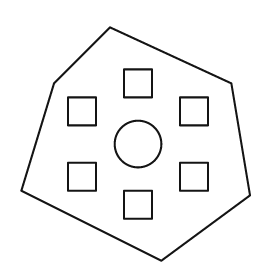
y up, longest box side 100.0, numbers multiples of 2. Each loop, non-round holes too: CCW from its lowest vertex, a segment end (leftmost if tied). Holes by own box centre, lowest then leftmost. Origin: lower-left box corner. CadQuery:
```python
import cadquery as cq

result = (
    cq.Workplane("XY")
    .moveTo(60.0, 0.0)
    .lineTo(98.0, 28.0)
    .lineTo(90.0, 76.0)
    .lineTo(38.0, 100.0)
    .lineTo(14.0, 76.0)
    .lineTo(0.0, 30.0)
    .close()
    .moveTo(44.0, 18.0)
    .lineTo(56.0, 18.0)
    .lineTo(56.0, 30.0)
    .lineTo(44.0, 30.0)
    .close()
    .moveTo(20.0, 30.0)
    .lineTo(32.0, 30.0)
    .lineTo(32.0, 42.0)
    .lineTo(20.0, 42.0)
    .close()
    .moveTo(68.0, 30.0)
    .lineTo(80.0, 30.0)
    .lineTo(80.0, 42.0)
    .lineTo(68.0, 42.0)
    .close()
    .moveTo(50.0, 50.0)
    .circle(10.0)
    .moveTo(20.0, 58.0)
    .lineTo(32.0, 58.0)
    .lineTo(32.0, 70.0)
    .lineTo(20.0, 70.0)
    .close()
    .moveTo(68.0, 58.0)
    .lineTo(80.0, 58.0)
    .lineTo(80.0, 70.0)
    .lineTo(68.0, 70.0)
    .close()
    .moveTo(44.0, 70.0)
    .lineTo(56.0, 70.0)
    .lineTo(56.0, 82.0)
    .lineTo(44.0, 82.0)
    .close()
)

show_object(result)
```